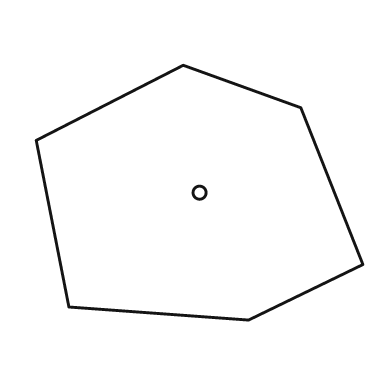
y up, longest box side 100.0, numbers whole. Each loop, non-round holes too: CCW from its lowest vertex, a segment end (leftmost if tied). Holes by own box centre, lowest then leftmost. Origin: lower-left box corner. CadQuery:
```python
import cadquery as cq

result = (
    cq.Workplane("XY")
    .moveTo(65.0, 0.0)
    .lineTo(100.0, 17.0)
    .lineTo(81.0, 65.0)
    .lineTo(45.0, 78.0)
    .lineTo(0.0, 55.0)
    .lineTo(10.0, 4.0)
    .close()
    .moveTo(50.0, 39.0)
    .circle(2.0)
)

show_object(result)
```